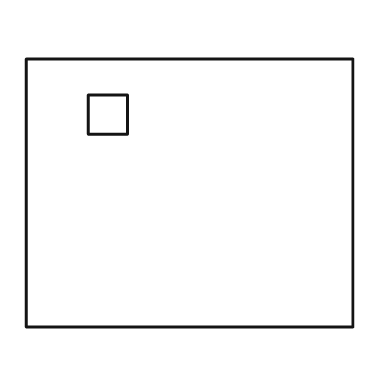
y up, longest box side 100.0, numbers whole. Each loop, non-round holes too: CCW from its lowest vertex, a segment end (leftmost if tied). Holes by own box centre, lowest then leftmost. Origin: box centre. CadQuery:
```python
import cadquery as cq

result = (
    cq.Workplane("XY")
    .moveTo(-50.0, -41.0)
    .lineTo(50.0, -41.0)
    .lineTo(50.0, 41.0)
    .lineTo(-50.0, 41.0)
    .close()
    .moveTo(-31.0, 18.0)
    .lineTo(-19.0, 18.0)
    .lineTo(-19.0, 30.0)
    .lineTo(-31.0, 30.0)
    .close()
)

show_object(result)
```